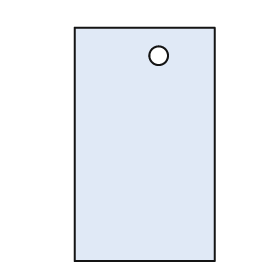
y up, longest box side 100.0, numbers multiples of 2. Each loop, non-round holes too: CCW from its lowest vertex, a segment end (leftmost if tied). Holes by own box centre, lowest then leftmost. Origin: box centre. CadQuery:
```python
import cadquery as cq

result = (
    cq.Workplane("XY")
    .moveTo(-30.0, -50.0)
    .lineTo(30.0, -50.0)
    .lineTo(30.0, 50.0)
    .lineTo(-30.0, 50.0)
    .close()
    .moveTo(6.0, 38.0)
    .circle(4.0)
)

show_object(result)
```